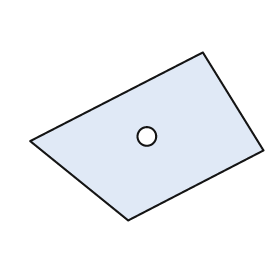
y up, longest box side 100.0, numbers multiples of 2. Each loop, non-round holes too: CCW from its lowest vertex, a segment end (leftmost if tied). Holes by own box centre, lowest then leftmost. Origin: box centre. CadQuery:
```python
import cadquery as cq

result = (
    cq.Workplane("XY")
    .moveTo(-8.0, -36.0)
    .lineTo(50.0, -6.0)
    .lineTo(24.0, 36.0)
    .lineTo(-50.0, -2.0)
    .close()
    .moveTo(0.0, 0.0)
    .circle(4.0)
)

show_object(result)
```